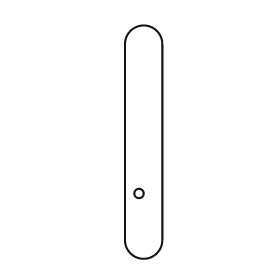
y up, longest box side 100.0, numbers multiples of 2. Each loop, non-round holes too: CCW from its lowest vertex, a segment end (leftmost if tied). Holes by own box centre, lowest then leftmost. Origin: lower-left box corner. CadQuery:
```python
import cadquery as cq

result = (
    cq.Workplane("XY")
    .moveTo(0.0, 8.0)
    .threePointArc((8.0, 0.0), (16.0, 8.0))
    .lineTo(16.0, 92.0)
    .threePointArc((8.0, 100.0), (0.0, 92.0))
    .close()
    .moveTo(6.0, 28.0)
    .circle(2.0)
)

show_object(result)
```